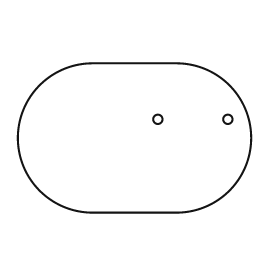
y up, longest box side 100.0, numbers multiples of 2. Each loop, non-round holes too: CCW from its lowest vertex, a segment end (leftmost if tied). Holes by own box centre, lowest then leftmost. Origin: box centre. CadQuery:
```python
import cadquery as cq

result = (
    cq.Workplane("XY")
    .moveTo(-18.0, -32.0)
    .lineTo(18.0, -32.0)
    .threePointArc((50.0, 0.0), (18.0, 32.0))
    .lineTo(-18.0, 32.0)
    .threePointArc((-50.0, 0.0), (-18.0, -32.0))
    .close()
    .moveTo(10.0, 8.0)
    .circle(2.0)
    .moveTo(40.0, 8.0)
    .circle(2.0)
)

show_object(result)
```